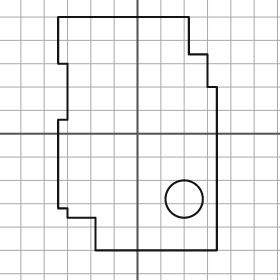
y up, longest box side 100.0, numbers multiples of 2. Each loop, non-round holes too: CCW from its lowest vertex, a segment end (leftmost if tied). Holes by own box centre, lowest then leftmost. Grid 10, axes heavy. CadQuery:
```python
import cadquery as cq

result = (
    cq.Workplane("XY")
    .moveTo(-18.0, -50.0)
    .lineTo(34.0, -50.0)
    .lineTo(34.0, 20.0)
    .lineTo(30.0, 20.0)
    .lineTo(30.0, 34.0)
    .lineTo(22.0, 34.0)
    .lineTo(22.0, 50.0)
    .lineTo(-34.0, 50.0)
    .lineTo(-34.0, 30.0)
    .lineTo(-30.0, 30.0)
    .lineTo(-30.0, 6.0)
    .lineTo(-34.0, 6.0)
    .lineTo(-34.0, -32.0)
    .lineTo(-30.0, -32.0)
    .lineTo(-30.0, -36.0)
    .lineTo(-18.0, -36.0)
    .close()
    .moveTo(20.0, -28.0)
    .circle(8.0)
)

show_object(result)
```